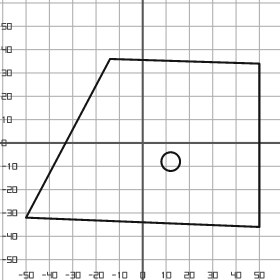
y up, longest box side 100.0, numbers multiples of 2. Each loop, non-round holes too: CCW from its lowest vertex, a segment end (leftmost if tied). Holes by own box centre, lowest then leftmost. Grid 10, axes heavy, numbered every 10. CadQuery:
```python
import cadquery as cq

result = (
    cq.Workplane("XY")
    .moveTo(50.0, -36.0)
    .lineTo(50.0, 34.0)
    .lineTo(-14.0, 36.0)
    .lineTo(-50.0, -32.0)
    .close()
    .moveTo(12.0, -8.0)
    .circle(4.0)
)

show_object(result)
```